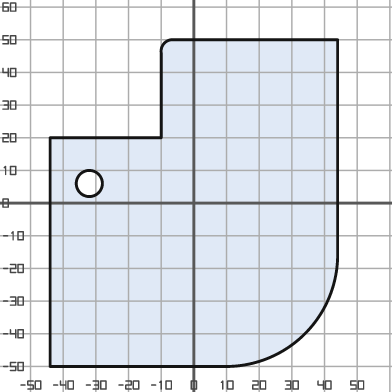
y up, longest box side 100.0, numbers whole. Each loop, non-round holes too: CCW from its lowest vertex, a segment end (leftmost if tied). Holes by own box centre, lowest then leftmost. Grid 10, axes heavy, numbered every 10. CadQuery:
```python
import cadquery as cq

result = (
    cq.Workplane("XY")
    .moveTo(-44.0, -50.0)
    .lineTo(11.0, -50.0)
    .threePointArc((34.0, -40.0), (44.0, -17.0))
    .lineTo(44.0, 50.0)
    .lineTo(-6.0, 50.0)
    .threePointArc((-9.0, 49.0), (-10.0, 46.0))
    .lineTo(-10.0, 20.0)
    .lineTo(-44.0, 20.0)
    .close()
    .moveTo(-32.0, 6.0)
    .circle(4.0)
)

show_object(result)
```